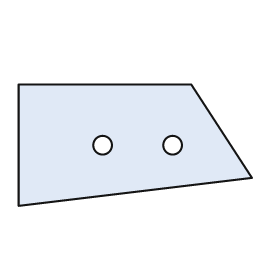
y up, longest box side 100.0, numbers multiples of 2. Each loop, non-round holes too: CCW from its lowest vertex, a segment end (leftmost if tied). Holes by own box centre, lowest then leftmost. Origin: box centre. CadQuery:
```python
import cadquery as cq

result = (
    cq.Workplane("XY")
    .moveTo(-50.0, -26.0)
    .lineTo(50.0, -14.0)
    .lineTo(24.0, 26.0)
    .lineTo(-50.0, 26.0)
    .close()
    .moveTo(-14.0, 0.0)
    .circle(4.0)
    .moveTo(16.0, 0.0)
    .circle(4.0)
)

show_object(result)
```